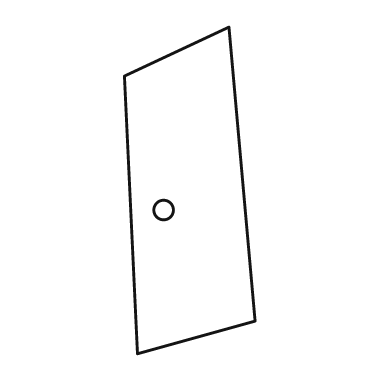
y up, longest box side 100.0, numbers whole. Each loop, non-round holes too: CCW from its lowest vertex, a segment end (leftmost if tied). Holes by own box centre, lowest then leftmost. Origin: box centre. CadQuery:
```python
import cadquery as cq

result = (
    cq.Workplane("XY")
    .moveTo(-16.0, -50.0)
    .lineTo(20.0, -40.0)
    .lineTo(12.0, 50.0)
    .lineTo(-20.0, 35.0)
    .close()
    .moveTo(-8.0, -6.0)
    .circle(3.0)
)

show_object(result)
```